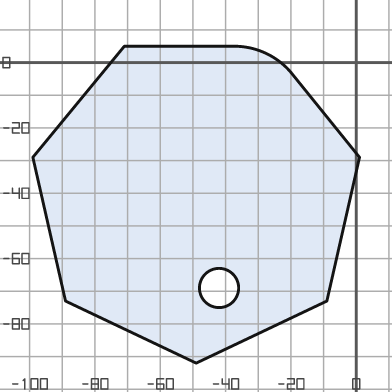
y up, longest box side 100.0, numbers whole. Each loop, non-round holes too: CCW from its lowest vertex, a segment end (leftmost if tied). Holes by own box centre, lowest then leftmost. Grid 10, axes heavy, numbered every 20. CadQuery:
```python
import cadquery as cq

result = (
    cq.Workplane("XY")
    .moveTo(-49.0, -92.0)
    .lineTo(-9.0, -73.0)
    .lineTo(1.0, -29.0)
    .lineTo(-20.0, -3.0)
    .threePointArc((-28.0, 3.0), (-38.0, 5.0))
    .lineTo(-71.0, 5.0)
    .lineTo(-99.0, -29.0)
    .lineTo(-89.0, -73.0)
    .close()
    .moveTo(-42.0, -69.0)
    .circle(6.0)
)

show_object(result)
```